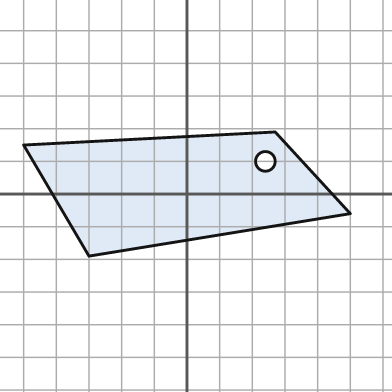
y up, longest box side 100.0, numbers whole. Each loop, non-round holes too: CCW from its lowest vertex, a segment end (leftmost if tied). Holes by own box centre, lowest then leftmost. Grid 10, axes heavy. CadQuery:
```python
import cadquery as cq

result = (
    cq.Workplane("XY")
    .moveTo(-30.0, -19.0)
    .lineTo(50.0, -6.0)
    .lineTo(27.0, 19.0)
    .lineTo(-50.0, 15.0)
    .close()
    .moveTo(24.0, 10.0)
    .circle(3.0)
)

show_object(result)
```